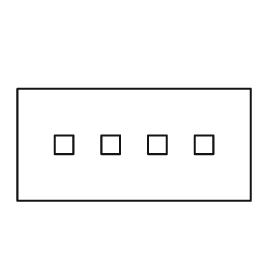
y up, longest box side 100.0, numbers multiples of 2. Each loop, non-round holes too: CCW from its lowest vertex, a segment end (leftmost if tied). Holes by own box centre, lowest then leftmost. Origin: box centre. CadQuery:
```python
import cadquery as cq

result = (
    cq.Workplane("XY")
    .moveTo(-50.0, -24.0)
    .lineTo(50.0, -24.0)
    .lineTo(50.0, 24.0)
    .lineTo(-50.0, 24.0)
    .close()
    .moveTo(-34.0, -4.0)
    .lineTo(-26.0, -4.0)
    .lineTo(-26.0, 4.0)
    .lineTo(-34.0, 4.0)
    .close()
    .moveTo(-14.0, -4.0)
    .lineTo(-6.0, -4.0)
    .lineTo(-6.0, 4.0)
    .lineTo(-14.0, 4.0)
    .close()
    .moveTo(6.0, -4.0)
    .lineTo(14.0, -4.0)
    .lineTo(14.0, 4.0)
    .lineTo(6.0, 4.0)
    .close()
    .moveTo(26.0, -4.0)
    .lineTo(34.0, -4.0)
    .lineTo(34.0, 4.0)
    .lineTo(26.0, 4.0)
    .close()
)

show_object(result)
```